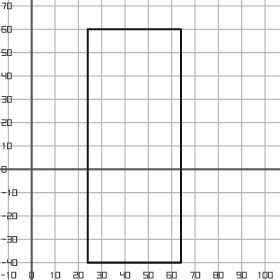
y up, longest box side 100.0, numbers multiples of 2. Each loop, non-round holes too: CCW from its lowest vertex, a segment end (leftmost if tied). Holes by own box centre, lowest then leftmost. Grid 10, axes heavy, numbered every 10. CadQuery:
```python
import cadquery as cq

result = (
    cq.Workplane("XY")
    .moveTo(24.0, -40.0)
    .lineTo(64.0, -40.0)
    .lineTo(64.0, 60.0)
    .lineTo(24.0, 60.0)
    .close()
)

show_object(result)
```